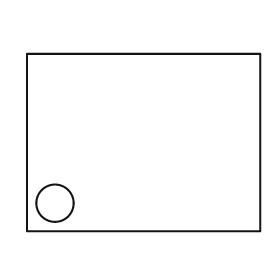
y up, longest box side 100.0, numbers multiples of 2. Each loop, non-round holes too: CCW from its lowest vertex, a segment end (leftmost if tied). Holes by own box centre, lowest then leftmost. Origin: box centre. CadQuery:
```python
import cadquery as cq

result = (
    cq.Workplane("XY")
    .moveTo(-50.0, -38.0)
    .lineTo(50.0, -38.0)
    .lineTo(50.0, 38.0)
    .lineTo(-50.0, 38.0)
    .close()
    .moveTo(-38.0, -26.0)
    .circle(8.0)
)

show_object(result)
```